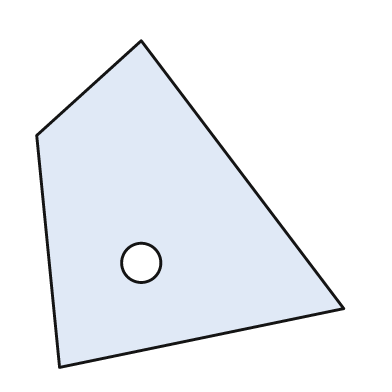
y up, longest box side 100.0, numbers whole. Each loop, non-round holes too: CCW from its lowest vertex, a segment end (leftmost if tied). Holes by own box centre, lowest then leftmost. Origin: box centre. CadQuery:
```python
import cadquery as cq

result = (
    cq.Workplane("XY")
    .moveTo(-40.0, -50.0)
    .lineTo(47.0, -32.0)
    .lineTo(-15.0, 50.0)
    .lineTo(-47.0, 21.0)
    .close()
    .moveTo(-15.0, -18.0)
    .circle(6.0)
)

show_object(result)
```